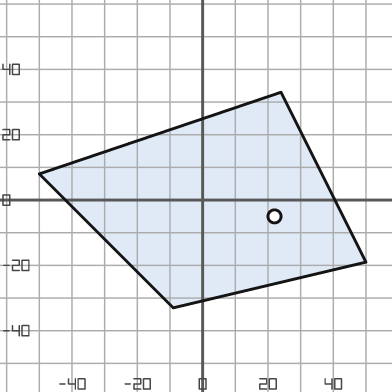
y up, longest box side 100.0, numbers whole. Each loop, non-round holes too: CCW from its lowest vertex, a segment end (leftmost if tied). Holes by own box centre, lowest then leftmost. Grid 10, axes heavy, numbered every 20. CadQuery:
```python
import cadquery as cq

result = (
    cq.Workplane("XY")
    .moveTo(-9.0, -33.0)
    .lineTo(50.0, -19.0)
    .lineTo(24.0, 33.0)
    .lineTo(-50.0, 8.0)
    .close()
    .moveTo(22.0, -5.0)
    .circle(2.0)
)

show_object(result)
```